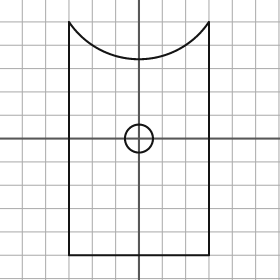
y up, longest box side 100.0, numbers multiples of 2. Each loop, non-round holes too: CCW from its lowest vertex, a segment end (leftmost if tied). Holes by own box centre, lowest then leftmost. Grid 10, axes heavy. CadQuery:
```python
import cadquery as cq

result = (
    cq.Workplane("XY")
    .moveTo(-30.0, -50.0)
    .lineTo(30.0, -50.0)
    .lineTo(30.0, 50.0)
    .threePointArc((0.0, 34.0), (-30.0, 50.0))
    .close()
    .moveTo(0.0, 0.0)
    .circle(6.0)
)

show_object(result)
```